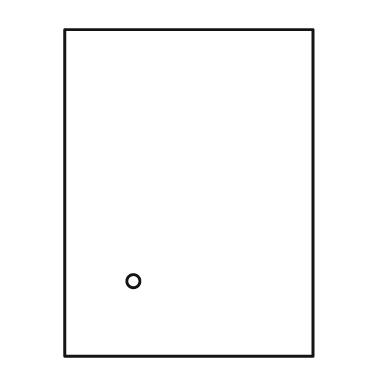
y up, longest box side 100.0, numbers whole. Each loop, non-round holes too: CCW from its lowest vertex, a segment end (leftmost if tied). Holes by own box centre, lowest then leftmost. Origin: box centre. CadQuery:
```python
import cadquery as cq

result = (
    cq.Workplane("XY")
    .moveTo(-38.0, -50.0)
    .lineTo(38.0, -50.0)
    .lineTo(38.0, 50.0)
    .lineTo(-38.0, 50.0)
    .close()
    .moveTo(-17.0, -27.0)
    .circle(2.0)
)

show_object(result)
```